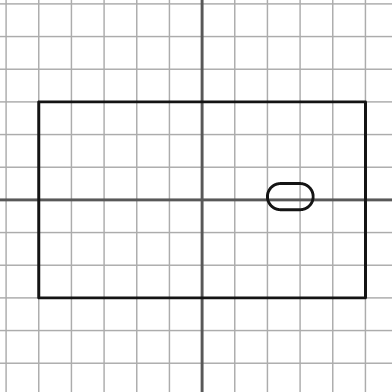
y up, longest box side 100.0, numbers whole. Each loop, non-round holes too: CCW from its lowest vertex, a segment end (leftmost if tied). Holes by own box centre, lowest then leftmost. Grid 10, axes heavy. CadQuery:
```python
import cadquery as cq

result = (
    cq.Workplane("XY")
    .moveTo(-50.0, -30.0)
    .lineTo(50.0, -30.0)
    .lineTo(50.0, 30.0)
    .lineTo(-50.0, 30.0)
    .close()
    .moveTo(24.0, -3.0)
    .lineTo(30.0, -3.0)
    .threePointArc((34.0, 1.0), (30.0, 5.0))
    .lineTo(24.0, 5.0)
    .threePointArc((20.0, 1.0), (24.0, -3.0))
    .close()
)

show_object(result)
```